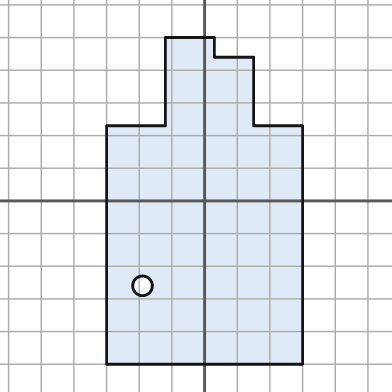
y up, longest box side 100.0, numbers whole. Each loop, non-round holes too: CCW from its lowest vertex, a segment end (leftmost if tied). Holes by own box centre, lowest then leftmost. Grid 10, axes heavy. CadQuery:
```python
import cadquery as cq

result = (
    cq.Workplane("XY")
    .moveTo(-30.0, -50.0)
    .lineTo(30.0, -50.0)
    .lineTo(30.0, 23.0)
    .lineTo(15.0, 23.0)
    .lineTo(15.0, 44.0)
    .lineTo(3.0, 44.0)
    .lineTo(3.0, 50.0)
    .lineTo(-12.0, 50.0)
    .lineTo(-12.0, 23.0)
    .lineTo(-30.0, 23.0)
    .close()
    .moveTo(-19.0, -26.0)
    .circle(3.0)
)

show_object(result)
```